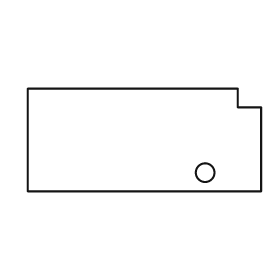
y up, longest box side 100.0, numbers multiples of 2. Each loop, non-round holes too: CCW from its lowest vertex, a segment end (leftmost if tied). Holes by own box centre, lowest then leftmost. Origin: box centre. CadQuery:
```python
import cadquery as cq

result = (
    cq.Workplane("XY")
    .moveTo(-50.0, -22.0)
    .lineTo(50.0, -22.0)
    .lineTo(50.0, 14.0)
    .lineTo(40.0, 14.0)
    .lineTo(40.0, 22.0)
    .lineTo(-50.0, 22.0)
    .close()
    .moveTo(26.0, -14.0)
    .circle(4.0)
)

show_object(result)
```